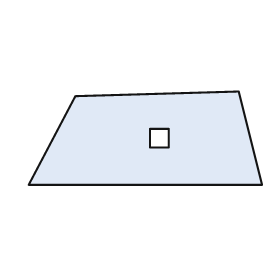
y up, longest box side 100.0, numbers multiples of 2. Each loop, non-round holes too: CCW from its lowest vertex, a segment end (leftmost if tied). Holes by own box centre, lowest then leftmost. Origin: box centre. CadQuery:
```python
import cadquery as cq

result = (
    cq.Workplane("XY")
    .moveTo(-50.0, -20.0)
    .lineTo(50.0, -20.0)
    .lineTo(40.0, 20.0)
    .lineTo(-30.0, 18.0)
    .close()
    .moveTo(2.0, -4.0)
    .lineTo(10.0, -4.0)
    .lineTo(10.0, 4.0)
    .lineTo(2.0, 4.0)
    .close()
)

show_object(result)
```